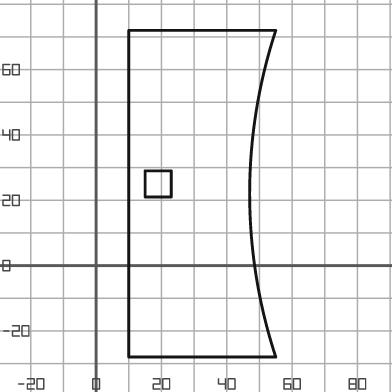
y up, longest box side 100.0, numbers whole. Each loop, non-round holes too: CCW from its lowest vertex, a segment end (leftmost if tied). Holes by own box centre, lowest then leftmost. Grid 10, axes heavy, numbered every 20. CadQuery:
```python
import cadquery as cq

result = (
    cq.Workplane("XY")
    .moveTo(10.0, -28.0)
    .lineTo(55.0, -28.0)
    .threePointArc((47.0, 22.0), (55.0, 72.0))
    .lineTo(10.0, 72.0)
    .close()
    .moveTo(15.0, 21.0)
    .lineTo(23.0, 21.0)
    .lineTo(23.0, 29.0)
    .lineTo(15.0, 29.0)
    .close()
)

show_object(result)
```